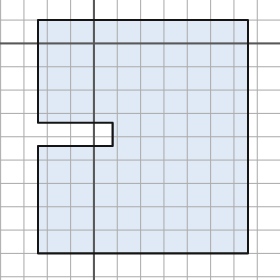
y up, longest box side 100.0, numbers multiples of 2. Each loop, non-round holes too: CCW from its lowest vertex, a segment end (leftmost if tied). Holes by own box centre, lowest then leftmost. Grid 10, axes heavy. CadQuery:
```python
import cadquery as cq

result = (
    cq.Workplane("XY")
    .moveTo(-24.0, -90.0)
    .lineTo(66.0, -90.0)
    .lineTo(66.0, 10.0)
    .lineTo(-24.0, 10.0)
    .lineTo(-24.0, -34.0)
    .lineTo(8.0, -34.0)
    .lineTo(8.0, -44.0)
    .lineTo(-24.0, -44.0)
    .close()
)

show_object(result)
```